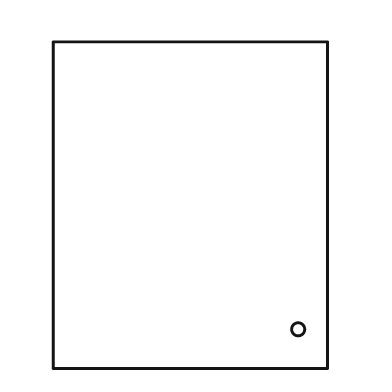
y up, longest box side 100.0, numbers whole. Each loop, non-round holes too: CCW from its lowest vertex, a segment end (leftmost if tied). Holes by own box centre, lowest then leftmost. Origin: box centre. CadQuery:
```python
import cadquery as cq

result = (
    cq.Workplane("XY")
    .moveTo(-42.0, -50.0)
    .lineTo(42.0, -50.0)
    .lineTo(42.0, 50.0)
    .lineTo(-42.0, 50.0)
    .close()
    .moveTo(33.0, -38.0)
    .circle(2.0)
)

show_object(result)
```